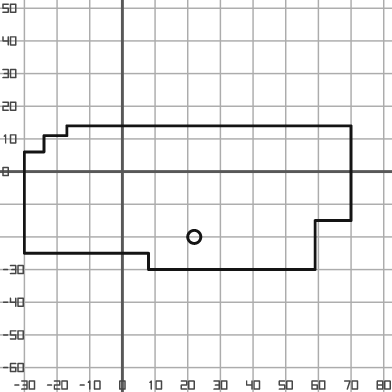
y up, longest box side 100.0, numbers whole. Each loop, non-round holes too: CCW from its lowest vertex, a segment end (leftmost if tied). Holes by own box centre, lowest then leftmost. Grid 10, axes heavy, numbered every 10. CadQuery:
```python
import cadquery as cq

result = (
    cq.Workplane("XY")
    .moveTo(8.0, -30.0)
    .lineTo(59.0, -30.0)
    .lineTo(59.0, -15.0)
    .lineTo(70.0, -15.0)
    .lineTo(70.0, 14.0)
    .lineTo(-17.0, 14.0)
    .lineTo(-17.0, 11.0)
    .lineTo(-24.0, 11.0)
    .lineTo(-24.0, 6.0)
    .lineTo(-30.0, 6.0)
    .lineTo(-30.0, -25.0)
    .lineTo(8.0, -25.0)
    .close()
    .moveTo(22.0, -20.0)
    .circle(2.0)
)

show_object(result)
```